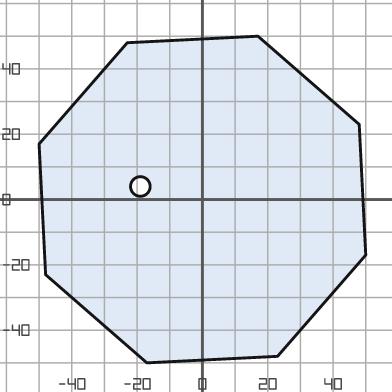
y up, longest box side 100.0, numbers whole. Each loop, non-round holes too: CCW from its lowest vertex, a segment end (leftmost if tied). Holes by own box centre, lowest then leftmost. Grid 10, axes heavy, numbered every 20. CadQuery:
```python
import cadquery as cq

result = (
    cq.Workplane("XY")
    .moveTo(-17.0, -50.0)
    .lineTo(23.0, -48.0)
    .lineTo(50.0, -17.0)
    .lineTo(48.0, 23.0)
    .lineTo(17.0, 50.0)
    .lineTo(-23.0, 48.0)
    .lineTo(-50.0, 17.0)
    .lineTo(-48.0, -23.0)
    .close()
    .moveTo(-19.0, 4.0)
    .circle(3.0)
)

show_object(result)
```